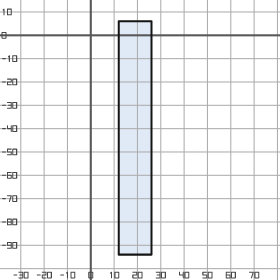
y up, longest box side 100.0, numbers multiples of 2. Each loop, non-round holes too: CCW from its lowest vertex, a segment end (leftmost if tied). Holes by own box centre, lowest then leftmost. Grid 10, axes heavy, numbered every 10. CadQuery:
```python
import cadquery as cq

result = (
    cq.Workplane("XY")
    .moveTo(12.0, -94.0)
    .lineTo(26.0, -94.0)
    .lineTo(26.0, 6.0)
    .lineTo(12.0, 6.0)
    .close()
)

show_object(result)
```